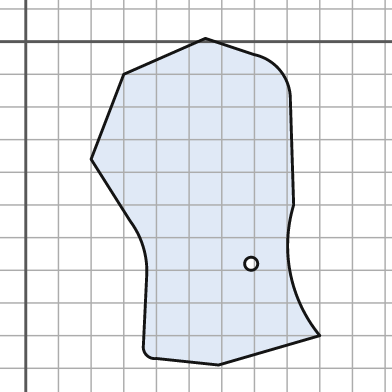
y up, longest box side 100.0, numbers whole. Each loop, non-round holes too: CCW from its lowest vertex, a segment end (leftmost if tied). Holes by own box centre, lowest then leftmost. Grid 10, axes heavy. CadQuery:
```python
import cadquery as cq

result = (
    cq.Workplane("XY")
    .moveTo(59.0, -99.0)
    .lineTo(90.0, -90.0)
    .threePointArc((81.0, -71.0), (82.0, -50.0))
    .lineTo(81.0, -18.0)
    .threePointArc((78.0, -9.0), (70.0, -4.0))
    .lineTo(55.0, 1.0)
    .lineTo(30.0, -10.0)
    .lineTo(20.0, -36.0)
    .lineTo(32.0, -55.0)
    .threePointArc((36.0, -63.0), (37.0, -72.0))
    .lineTo(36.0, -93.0)
    .threePointArc((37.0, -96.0), (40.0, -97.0))
    .close()
    .moveTo(69.0, -68.0)
    .circle(2.0)
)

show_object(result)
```